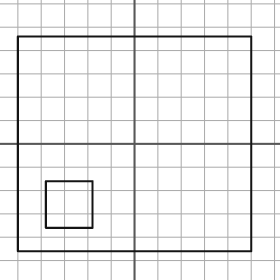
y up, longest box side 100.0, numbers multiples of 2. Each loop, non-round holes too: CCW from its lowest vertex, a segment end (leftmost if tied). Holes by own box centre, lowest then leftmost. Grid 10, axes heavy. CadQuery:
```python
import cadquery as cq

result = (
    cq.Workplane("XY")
    .moveTo(-50.0, -46.0)
    .lineTo(50.0, -46.0)
    .lineTo(50.0, 46.0)
    .lineTo(-50.0, 46.0)
    .close()
    .moveTo(-38.0, -36.0)
    .lineTo(-18.0, -36.0)
    .lineTo(-18.0, -16.0)
    .lineTo(-38.0, -16.0)
    .close()
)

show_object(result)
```